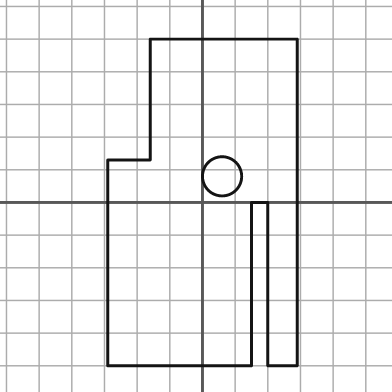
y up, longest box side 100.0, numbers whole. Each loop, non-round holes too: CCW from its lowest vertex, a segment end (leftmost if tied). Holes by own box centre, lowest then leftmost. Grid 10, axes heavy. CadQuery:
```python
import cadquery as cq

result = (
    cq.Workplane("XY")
    .moveTo(-29.0, -50.0)
    .lineTo(15.0, -50.0)
    .lineTo(15.0, 0.0)
    .lineTo(20.0, 0.0)
    .lineTo(20.0, -50.0)
    .lineTo(29.0, -50.0)
    .lineTo(29.0, 50.0)
    .lineTo(-16.0, 50.0)
    .lineTo(-16.0, 13.0)
    .lineTo(-29.0, 13.0)
    .close()
    .moveTo(6.0, 8.0)
    .circle(6.0)
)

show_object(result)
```